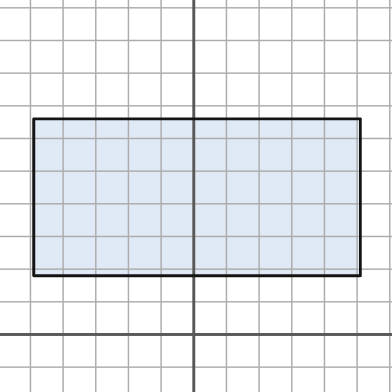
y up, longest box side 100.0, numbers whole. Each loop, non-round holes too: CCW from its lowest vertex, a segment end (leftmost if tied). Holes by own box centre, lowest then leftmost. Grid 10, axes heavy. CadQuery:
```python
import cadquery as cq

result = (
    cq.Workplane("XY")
    .moveTo(-49.0, 18.0)
    .lineTo(51.0, 18.0)
    .lineTo(51.0, 66.0)
    .lineTo(-49.0, 66.0)
    .close()
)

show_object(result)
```